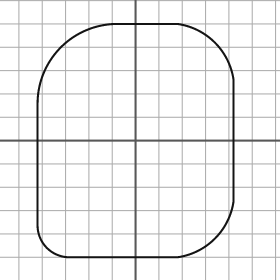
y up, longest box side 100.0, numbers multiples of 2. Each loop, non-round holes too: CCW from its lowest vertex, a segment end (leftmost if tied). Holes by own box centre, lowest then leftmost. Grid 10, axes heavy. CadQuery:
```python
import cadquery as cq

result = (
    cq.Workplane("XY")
    .moveTo(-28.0, -50.0)
    .lineTo(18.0, -50.0)
    .threePointArc((34.0, -42.0), (42.0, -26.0))
    .lineTo(42.0, 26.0)
    .threePointArc((34.0, 42.0), (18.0, 50.0))
    .lineTo(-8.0, 50.0)
    .threePointArc((-32.0, 40.0), (-42.0, 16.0))
    .lineTo(-42.0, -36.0)
    .threePointArc((-38.0, -46.0), (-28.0, -50.0))
    .close()
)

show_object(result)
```